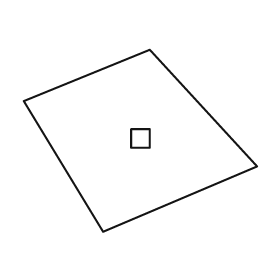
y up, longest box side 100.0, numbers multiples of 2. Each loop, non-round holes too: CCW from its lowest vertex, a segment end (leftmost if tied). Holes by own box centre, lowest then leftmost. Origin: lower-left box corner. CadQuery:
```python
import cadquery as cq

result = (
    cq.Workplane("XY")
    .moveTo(34.0, 0.0)
    .lineTo(100.0, 28.0)
    .lineTo(54.0, 78.0)
    .lineTo(0.0, 56.0)
    .close()
    .moveTo(46.0, 36.0)
    .lineTo(54.0, 36.0)
    .lineTo(54.0, 44.0)
    .lineTo(46.0, 44.0)
    .close()
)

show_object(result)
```